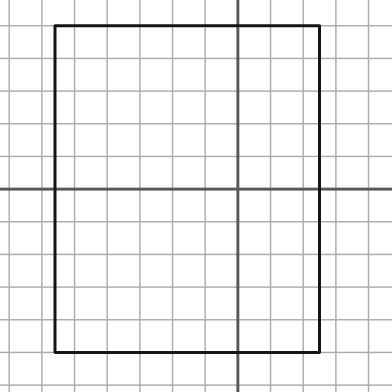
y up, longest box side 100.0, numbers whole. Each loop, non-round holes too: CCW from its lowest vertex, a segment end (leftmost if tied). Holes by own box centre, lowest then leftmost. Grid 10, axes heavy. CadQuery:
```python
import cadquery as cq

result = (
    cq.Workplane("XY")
    .moveTo(-56.0, -50.0)
    .lineTo(25.0, -50.0)
    .lineTo(25.0, 50.0)
    .lineTo(-56.0, 50.0)
    .close()
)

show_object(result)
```